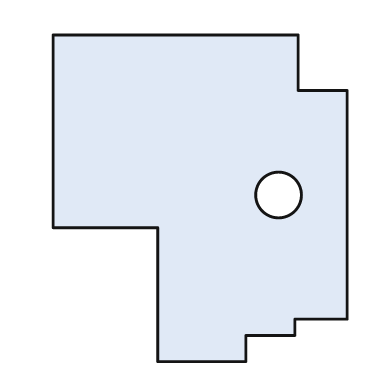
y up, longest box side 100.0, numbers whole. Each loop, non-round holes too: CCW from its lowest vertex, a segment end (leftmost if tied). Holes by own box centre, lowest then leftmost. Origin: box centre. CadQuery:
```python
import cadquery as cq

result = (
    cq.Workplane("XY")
    .moveTo(-13.0, -50.0)
    .lineTo(14.0, -50.0)
    .lineTo(14.0, -42.0)
    .lineTo(29.0, -42.0)
    .lineTo(29.0, -37.0)
    .lineTo(45.0, -37.0)
    .lineTo(45.0, 33.0)
    .lineTo(30.0, 33.0)
    .lineTo(30.0, 50.0)
    .lineTo(-45.0, 50.0)
    .lineTo(-45.0, -9.0)
    .lineTo(-13.0, -9.0)
    .close()
    .moveTo(24.0, 1.0)
    .circle(7.0)
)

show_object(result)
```